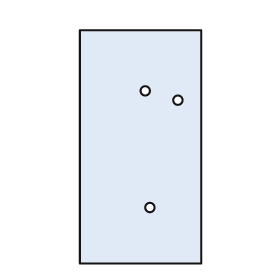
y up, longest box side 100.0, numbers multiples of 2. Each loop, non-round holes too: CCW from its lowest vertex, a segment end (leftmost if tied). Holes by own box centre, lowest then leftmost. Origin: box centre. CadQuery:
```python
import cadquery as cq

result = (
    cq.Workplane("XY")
    .moveTo(-26.0, -50.0)
    .lineTo(26.0, -50.0)
    .lineTo(26.0, 50.0)
    .lineTo(-26.0, 50.0)
    .close()
    .moveTo(4.0, -26.0)
    .circle(2.0)
    .moveTo(16.0, 20.0)
    .circle(2.0)
    .moveTo(2.0, 24.0)
    .circle(2.0)
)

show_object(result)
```